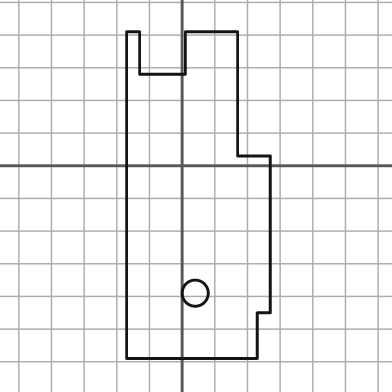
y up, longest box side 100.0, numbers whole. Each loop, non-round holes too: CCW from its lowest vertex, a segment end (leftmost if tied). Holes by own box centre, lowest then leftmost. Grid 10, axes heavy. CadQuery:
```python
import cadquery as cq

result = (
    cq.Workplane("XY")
    .moveTo(-17.0, -59.0)
    .lineTo(23.0, -59.0)
    .lineTo(23.0, -45.0)
    .lineTo(27.0, -45.0)
    .lineTo(27.0, 3.0)
    .lineTo(17.0, 3.0)
    .lineTo(17.0, 41.0)
    .lineTo(1.0, 41.0)
    .lineTo(1.0, 28.0)
    .lineTo(-13.0, 28.0)
    .lineTo(-13.0, 41.0)
    .lineTo(-17.0, 41.0)
    .close()
    .moveTo(4.0, -39.0)
    .circle(4.0)
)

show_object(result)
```